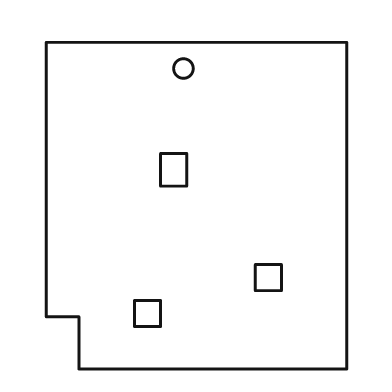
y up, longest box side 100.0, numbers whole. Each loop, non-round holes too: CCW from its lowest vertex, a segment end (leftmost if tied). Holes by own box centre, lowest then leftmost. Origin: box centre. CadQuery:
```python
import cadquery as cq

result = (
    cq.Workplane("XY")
    .moveTo(-36.0, -50.0)
    .lineTo(46.0, -50.0)
    .lineTo(46.0, 50.0)
    .lineTo(-46.0, 50.0)
    .lineTo(-46.0, -34.0)
    .lineTo(-36.0, -34.0)
    .close()
    .moveTo(-19.0, -37.0)
    .lineTo(-11.0, -37.0)
    .lineTo(-11.0, -29.0)
    .lineTo(-19.0, -29.0)
    .close()
    .moveTo(18.0, -26.0)
    .lineTo(26.0, -26.0)
    .lineTo(26.0, -18.0)
    .lineTo(18.0, -18.0)
    .close()
    .moveTo(-11.0, 6.0)
    .lineTo(-3.0, 6.0)
    .lineTo(-3.0, 16.0)
    .lineTo(-11.0, 16.0)
    .close()
    .moveTo(-4.0, 42.0)
    .circle(3.0)
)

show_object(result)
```